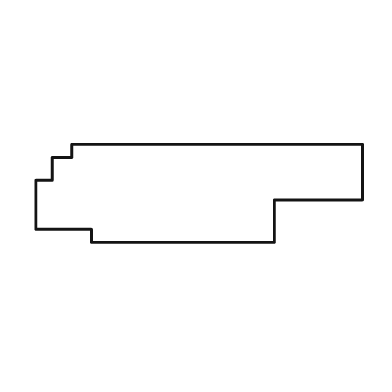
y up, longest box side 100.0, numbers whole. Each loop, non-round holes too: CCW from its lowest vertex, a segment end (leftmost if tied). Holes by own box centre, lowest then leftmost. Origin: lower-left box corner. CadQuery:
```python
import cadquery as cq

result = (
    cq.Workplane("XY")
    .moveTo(17.0, 0.0)
    .lineTo(73.0, 0.0)
    .lineTo(73.0, 13.0)
    .lineTo(100.0, 13.0)
    .lineTo(100.0, 30.0)
    .lineTo(11.0, 30.0)
    .lineTo(11.0, 26.0)
    .lineTo(5.0, 26.0)
    .lineTo(5.0, 19.0)
    .lineTo(0.0, 19.0)
    .lineTo(0.0, 4.0)
    .lineTo(17.0, 4.0)
    .close()
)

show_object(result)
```